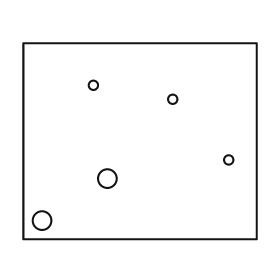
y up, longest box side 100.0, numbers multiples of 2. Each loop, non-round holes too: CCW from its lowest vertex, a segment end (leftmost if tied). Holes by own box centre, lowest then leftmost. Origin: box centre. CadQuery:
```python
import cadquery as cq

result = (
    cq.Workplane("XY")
    .moveTo(-50.0, -42.0)
    .lineTo(50.0, -42.0)
    .lineTo(50.0, 42.0)
    .lineTo(-50.0, 42.0)
    .close()
    .moveTo(-42.0, -34.0)
    .circle(4.0)
    .moveTo(-14.0, -16.0)
    .circle(4.0)
    .moveTo(38.0, -8.0)
    .circle(2.0)
    .moveTo(14.0, 18.0)
    .circle(2.0)
    .moveTo(-20.0, 24.0)
    .circle(2.0)
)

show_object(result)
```